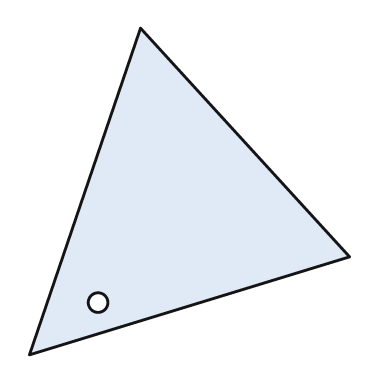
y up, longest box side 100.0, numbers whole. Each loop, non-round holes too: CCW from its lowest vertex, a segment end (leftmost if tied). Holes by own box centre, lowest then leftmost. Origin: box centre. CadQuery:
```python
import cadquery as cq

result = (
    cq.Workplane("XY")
    .moveTo(-49.0, -50.0)
    .lineTo(49.0, -20.0)
    .lineTo(-15.0, 50.0)
    .close()
    .moveTo(-28.0, -34.0)
    .circle(3.0)
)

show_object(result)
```